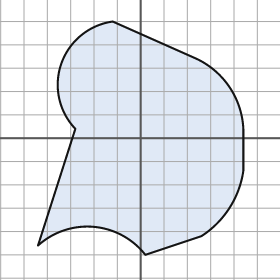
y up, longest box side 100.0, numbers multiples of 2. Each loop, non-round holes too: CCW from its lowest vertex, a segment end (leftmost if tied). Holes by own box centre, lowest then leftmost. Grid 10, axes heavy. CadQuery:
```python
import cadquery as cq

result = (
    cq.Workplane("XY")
    .moveTo(2.0, -50.0)
    .lineTo(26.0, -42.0)
    .threePointArc((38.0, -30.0), (44.0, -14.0))
    .lineTo(44.0, 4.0)
    .threePointArc((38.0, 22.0), (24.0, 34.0))
    .lineTo(-12.0, 50.0)
    .threePointArc((-34.0, 32.0), (-28.0, 4.0))
    .lineTo(-44.0, -46.0)
    .threePointArc((-20.0, -38.0), (2.0, -50.0))
    .close()
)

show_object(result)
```